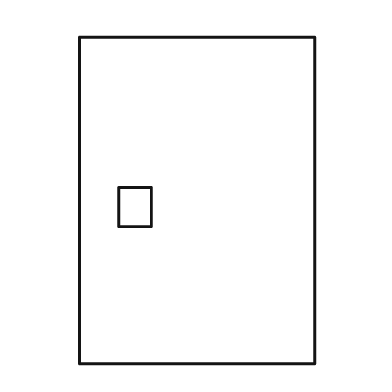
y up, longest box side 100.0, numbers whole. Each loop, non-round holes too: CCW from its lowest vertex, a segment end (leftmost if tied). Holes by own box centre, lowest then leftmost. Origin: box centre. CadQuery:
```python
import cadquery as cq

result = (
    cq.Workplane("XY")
    .moveTo(-36.0, -50.0)
    .lineTo(36.0, -50.0)
    .lineTo(36.0, 50.0)
    .lineTo(-36.0, 50.0)
    .close()
    .moveTo(-24.0, -8.0)
    .lineTo(-14.0, -8.0)
    .lineTo(-14.0, 4.0)
    .lineTo(-24.0, 4.0)
    .close()
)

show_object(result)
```